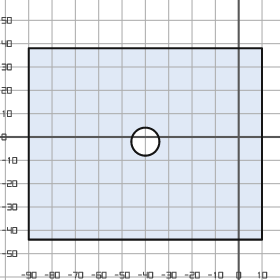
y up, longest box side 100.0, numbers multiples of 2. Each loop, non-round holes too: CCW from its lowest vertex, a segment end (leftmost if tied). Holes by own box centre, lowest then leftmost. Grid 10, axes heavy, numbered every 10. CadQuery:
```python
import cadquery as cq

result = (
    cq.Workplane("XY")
    .moveTo(-90.0, -44.0)
    .lineTo(10.0, -44.0)
    .lineTo(10.0, 38.0)
    .lineTo(-90.0, 38.0)
    .close()
    .moveTo(-40.0, -2.0)
    .circle(6.0)
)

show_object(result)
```